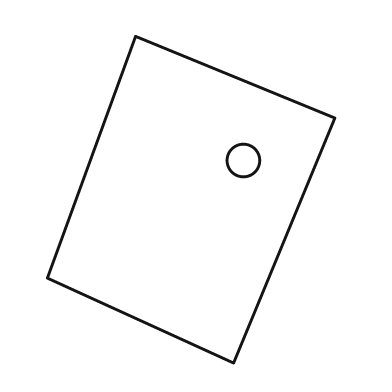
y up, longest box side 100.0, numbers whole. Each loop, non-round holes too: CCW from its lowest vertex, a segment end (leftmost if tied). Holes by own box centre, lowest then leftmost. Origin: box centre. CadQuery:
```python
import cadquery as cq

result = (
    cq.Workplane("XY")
    .moveTo(13.0, -50.0)
    .lineTo(44.0, 25.0)
    .lineTo(-17.0, 50.0)
    .lineTo(-44.0, -24.0)
    .close()
    .moveTo(16.0, 12.0)
    .circle(5.0)
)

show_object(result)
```